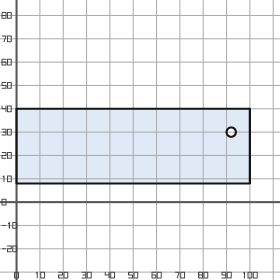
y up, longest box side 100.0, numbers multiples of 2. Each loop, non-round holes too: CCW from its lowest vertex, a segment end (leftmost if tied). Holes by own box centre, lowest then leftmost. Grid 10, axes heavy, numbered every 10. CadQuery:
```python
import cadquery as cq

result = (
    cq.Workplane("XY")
    .moveTo(0.0, 8.0)
    .lineTo(100.0, 8.0)
    .lineTo(100.0, 40.0)
    .lineTo(0.0, 40.0)
    .close()
    .moveTo(92.0, 30.0)
    .circle(2.0)
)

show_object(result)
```